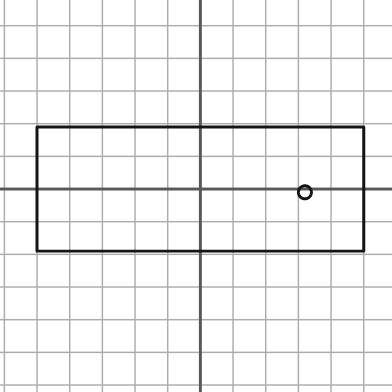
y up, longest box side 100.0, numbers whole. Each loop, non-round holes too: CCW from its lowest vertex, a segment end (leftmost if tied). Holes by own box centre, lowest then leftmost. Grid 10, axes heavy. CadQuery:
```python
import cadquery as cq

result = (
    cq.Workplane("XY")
    .moveTo(-50.0, -19.0)
    .lineTo(50.0, -19.0)
    .lineTo(50.0, 19.0)
    .lineTo(-50.0, 19.0)
    .close()
    .moveTo(32.0, -1.0)
    .circle(2.0)
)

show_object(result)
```